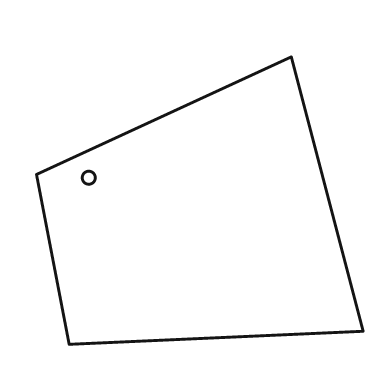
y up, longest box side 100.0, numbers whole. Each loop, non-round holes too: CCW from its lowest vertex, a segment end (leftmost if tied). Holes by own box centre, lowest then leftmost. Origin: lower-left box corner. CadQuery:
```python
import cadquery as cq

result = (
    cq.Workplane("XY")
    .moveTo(10.0, 0.0)
    .lineTo(100.0, 4.0)
    .lineTo(78.0, 88.0)
    .lineTo(0.0, 52.0)
    .close()
    .moveTo(16.0, 51.0)
    .circle(2.0)
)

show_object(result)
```